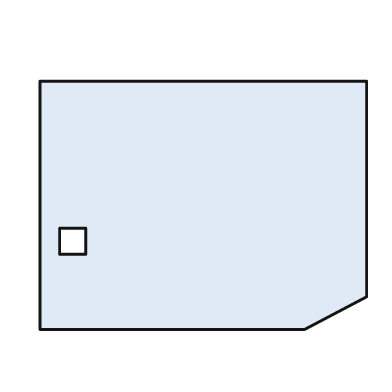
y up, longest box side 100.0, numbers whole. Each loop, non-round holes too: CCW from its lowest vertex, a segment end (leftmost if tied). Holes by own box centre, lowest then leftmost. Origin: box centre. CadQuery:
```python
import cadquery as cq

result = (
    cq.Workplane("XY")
    .moveTo(-50.0, -38.0)
    .lineTo(31.0, -38.0)
    .lineTo(50.0, -28.0)
    .lineTo(50.0, 38.0)
    .lineTo(-50.0, 38.0)
    .close()
    .moveTo(-44.0, -15.0)
    .lineTo(-36.0, -15.0)
    .lineTo(-36.0, -7.0)
    .lineTo(-44.0, -7.0)
    .close()
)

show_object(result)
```